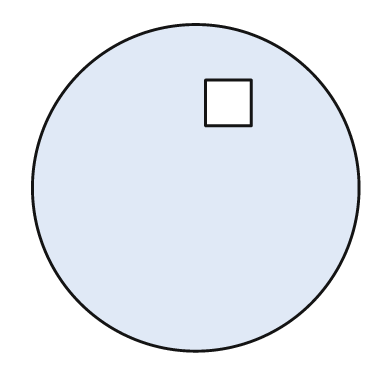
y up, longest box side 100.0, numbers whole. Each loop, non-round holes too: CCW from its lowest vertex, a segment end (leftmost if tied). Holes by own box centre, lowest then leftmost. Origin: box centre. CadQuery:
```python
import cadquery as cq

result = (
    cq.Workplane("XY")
    .moveTo(0.0, 0.0)
    .circle(50.0)
    .moveTo(3.0, 19.0)
    .lineTo(17.0, 19.0)
    .lineTo(17.0, 33.0)
    .lineTo(3.0, 33.0)
    .close()
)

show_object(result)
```